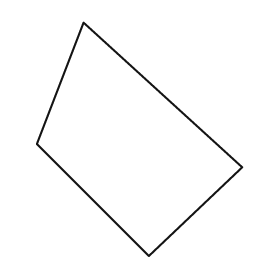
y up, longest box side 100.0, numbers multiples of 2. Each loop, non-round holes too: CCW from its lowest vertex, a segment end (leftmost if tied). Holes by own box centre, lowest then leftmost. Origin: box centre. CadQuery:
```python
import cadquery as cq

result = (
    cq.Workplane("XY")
    .moveTo(4.0, -50.0)
    .lineTo(44.0, -12.0)
    .lineTo(-24.0, 50.0)
    .lineTo(-44.0, -2.0)
    .close()
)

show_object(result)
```